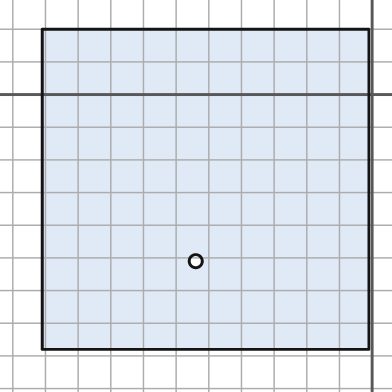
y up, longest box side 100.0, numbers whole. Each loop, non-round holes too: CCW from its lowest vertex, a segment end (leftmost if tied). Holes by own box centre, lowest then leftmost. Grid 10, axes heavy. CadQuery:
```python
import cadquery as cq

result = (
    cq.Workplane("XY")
    .moveTo(-101.0, -78.0)
    .lineTo(-1.0, -78.0)
    .lineTo(-1.0, 20.0)
    .lineTo(-101.0, 20.0)
    .close()
    .moveTo(-54.0, -51.0)
    .circle(2.0)
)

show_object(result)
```